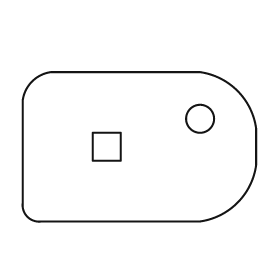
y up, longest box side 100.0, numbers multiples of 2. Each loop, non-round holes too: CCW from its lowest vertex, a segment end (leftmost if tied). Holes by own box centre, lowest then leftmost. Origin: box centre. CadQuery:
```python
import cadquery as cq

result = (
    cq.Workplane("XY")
    .moveTo(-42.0, -32.0)
    .lineTo(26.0, -32.0)
    .threePointArc((42.0, -24.0), (50.0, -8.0))
    .lineTo(50.0, 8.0)
    .threePointArc((42.0, 24.0), (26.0, 32.0))
    .lineTo(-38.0, 32.0)
    .threePointArc((-46.0, 28.0), (-50.0, 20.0))
    .lineTo(-50.0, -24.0)
    .threePointArc((-48.0, -30.0), (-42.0, -32.0))
    .close()
    .moveTo(-20.0, -6.0)
    .lineTo(-8.0, -6.0)
    .lineTo(-8.0, 6.0)
    .lineTo(-20.0, 6.0)
    .close()
    .moveTo(26.0, 12.0)
    .circle(6.0)
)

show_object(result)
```